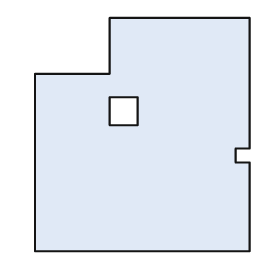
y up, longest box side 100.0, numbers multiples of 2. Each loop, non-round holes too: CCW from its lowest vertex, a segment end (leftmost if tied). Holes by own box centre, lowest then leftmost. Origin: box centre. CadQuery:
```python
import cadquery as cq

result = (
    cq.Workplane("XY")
    .moveTo(-46.0, -50.0)
    .lineTo(46.0, -50.0)
    .lineTo(46.0, -12.0)
    .lineTo(40.0, -12.0)
    .lineTo(40.0, -6.0)
    .lineTo(46.0, -6.0)
    .lineTo(46.0, 50.0)
    .lineTo(-14.0, 50.0)
    .lineTo(-14.0, 26.0)
    .lineTo(-46.0, 26.0)
    .close()
    .moveTo(-14.0, 4.0)
    .lineTo(-2.0, 4.0)
    .lineTo(-2.0, 16.0)
    .lineTo(-14.0, 16.0)
    .close()
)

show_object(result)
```